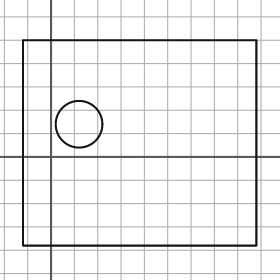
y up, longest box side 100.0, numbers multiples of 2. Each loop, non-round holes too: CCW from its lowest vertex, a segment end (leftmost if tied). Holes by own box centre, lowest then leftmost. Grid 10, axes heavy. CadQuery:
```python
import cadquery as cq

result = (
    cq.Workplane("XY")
    .moveTo(-12.0, -38.0)
    .lineTo(88.0, -38.0)
    .lineTo(88.0, 50.0)
    .lineTo(-12.0, 50.0)
    .close()
    .moveTo(12.0, 14.0)
    .circle(10.0)
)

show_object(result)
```